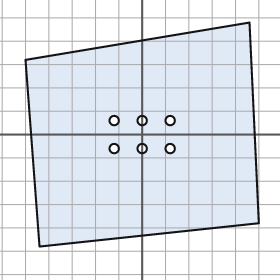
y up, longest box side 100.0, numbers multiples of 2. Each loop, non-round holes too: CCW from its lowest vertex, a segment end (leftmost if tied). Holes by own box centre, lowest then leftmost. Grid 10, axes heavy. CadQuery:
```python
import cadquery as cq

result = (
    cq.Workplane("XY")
    .moveTo(-44.0, -48.0)
    .lineTo(50.0, -38.0)
    .lineTo(46.0, 48.0)
    .lineTo(-50.0, 32.0)
    .close()
    .moveTo(-12.0, -6.0)
    .circle(2.0)
    .moveTo(0.0, -6.0)
    .circle(2.0)
    .moveTo(12.0, -6.0)
    .circle(2.0)
    .moveTo(-12.0, 6.0)
    .circle(2.0)
    .moveTo(0.0, 6.0)
    .circle(2.0)
    .moveTo(12.0, 6.0)
    .circle(2.0)
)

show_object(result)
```